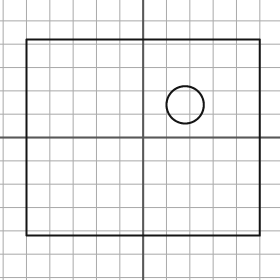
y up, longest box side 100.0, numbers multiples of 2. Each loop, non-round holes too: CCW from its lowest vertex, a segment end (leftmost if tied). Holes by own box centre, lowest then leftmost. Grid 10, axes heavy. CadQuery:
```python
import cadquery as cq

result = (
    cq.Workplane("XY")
    .moveTo(-50.0, -42.0)
    .lineTo(50.0, -42.0)
    .lineTo(50.0, 42.0)
    .lineTo(-50.0, 42.0)
    .close()
    .moveTo(18.0, 14.0)
    .circle(8.0)
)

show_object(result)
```